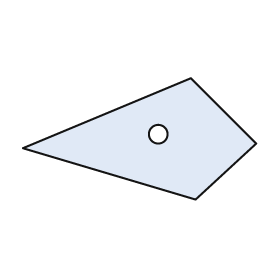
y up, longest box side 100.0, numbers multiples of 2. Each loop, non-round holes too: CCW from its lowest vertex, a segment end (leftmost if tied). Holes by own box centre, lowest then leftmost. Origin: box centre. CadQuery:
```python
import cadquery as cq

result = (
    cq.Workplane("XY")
    .moveTo(24.0, -26.0)
    .lineTo(50.0, -2.0)
    .lineTo(22.0, 26.0)
    .lineTo(-50.0, -4.0)
    .close()
    .moveTo(8.0, 2.0)
    .circle(4.0)
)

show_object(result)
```